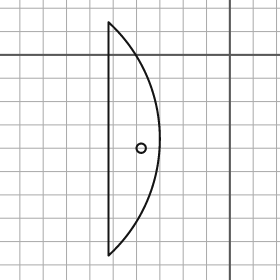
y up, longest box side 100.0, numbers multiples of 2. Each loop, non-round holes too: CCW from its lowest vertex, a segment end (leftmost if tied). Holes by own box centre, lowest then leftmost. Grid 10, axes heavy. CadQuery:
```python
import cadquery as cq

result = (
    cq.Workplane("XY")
    .moveTo(-52.0, -86.0)
    .threePointArc((-30.0, -36.0), (-52.0, 14.0))
    .close()
    .moveTo(-38.0, -40.0)
    .circle(2.0)
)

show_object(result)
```